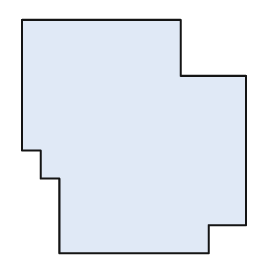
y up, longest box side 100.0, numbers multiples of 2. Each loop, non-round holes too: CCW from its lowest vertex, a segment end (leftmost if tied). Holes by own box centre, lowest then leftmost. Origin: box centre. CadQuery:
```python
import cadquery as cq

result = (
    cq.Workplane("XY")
    .moveTo(-32.0, -50.0)
    .lineTo(32.0, -50.0)
    .lineTo(32.0, -38.0)
    .lineTo(48.0, -38.0)
    .lineTo(48.0, 26.0)
    .lineTo(20.0, 26.0)
    .lineTo(20.0, 50.0)
    .lineTo(-48.0, 50.0)
    .lineTo(-48.0, -6.0)
    .lineTo(-40.0, -6.0)
    .lineTo(-40.0, -18.0)
    .lineTo(-32.0, -18.0)
    .close()
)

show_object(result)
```